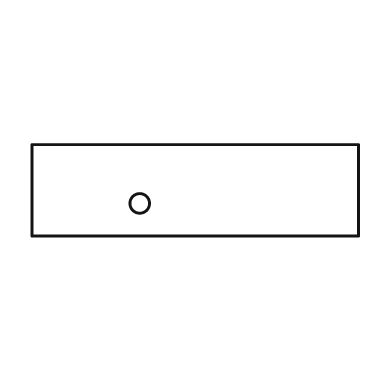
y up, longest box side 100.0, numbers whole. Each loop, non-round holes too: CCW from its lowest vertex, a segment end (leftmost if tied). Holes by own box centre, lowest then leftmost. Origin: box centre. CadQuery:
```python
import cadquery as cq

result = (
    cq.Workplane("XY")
    .moveTo(-50.0, -14.0)
    .lineTo(50.0, -14.0)
    .lineTo(50.0, 14.0)
    .lineTo(-50.0, 14.0)
    .close()
    .moveTo(-17.0, -4.0)
    .circle(3.0)
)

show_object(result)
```